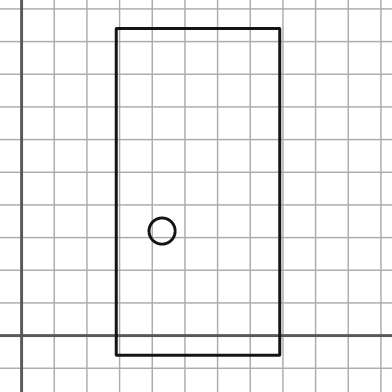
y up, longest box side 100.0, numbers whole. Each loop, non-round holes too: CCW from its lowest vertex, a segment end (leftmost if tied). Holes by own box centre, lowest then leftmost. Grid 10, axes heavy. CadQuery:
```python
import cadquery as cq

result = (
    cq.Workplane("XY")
    .moveTo(29.0, -6.0)
    .lineTo(79.0, -6.0)
    .lineTo(79.0, 94.0)
    .lineTo(29.0, 94.0)
    .close()
    .moveTo(43.0, 32.0)
    .circle(4.0)
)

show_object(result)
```